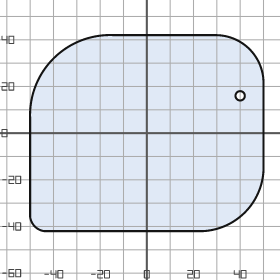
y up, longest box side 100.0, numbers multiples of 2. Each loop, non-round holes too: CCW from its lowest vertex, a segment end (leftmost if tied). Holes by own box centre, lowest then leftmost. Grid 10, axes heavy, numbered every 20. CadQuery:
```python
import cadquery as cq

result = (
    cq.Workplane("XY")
    .moveTo(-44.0, -42.0)
    .lineTo(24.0, -42.0)
    .threePointArc((42.0, -34.0), (50.0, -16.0))
    .lineTo(50.0, 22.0)
    .threePointArc((44.0, 36.0), (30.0, 42.0))
    .lineTo(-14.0, 42.0)
    .threePointArc((-40.0, 32.0), (-50.0, 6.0))
    .lineTo(-50.0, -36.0)
    .threePointArc((-48.0, -40.0), (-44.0, -42.0))
    .close()
    .moveTo(40.0, 16.0)
    .circle(2.0)
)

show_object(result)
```